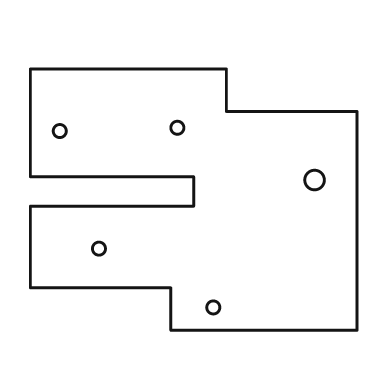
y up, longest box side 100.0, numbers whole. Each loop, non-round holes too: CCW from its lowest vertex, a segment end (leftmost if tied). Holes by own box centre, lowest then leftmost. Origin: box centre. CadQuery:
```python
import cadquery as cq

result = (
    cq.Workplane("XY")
    .moveTo(-7.0, -40.0)
    .lineTo(50.0, -40.0)
    .lineTo(50.0, 27.0)
    .lineTo(10.0, 27.0)
    .lineTo(10.0, 40.0)
    .lineTo(-50.0, 40.0)
    .lineTo(-50.0, 7.0)
    .lineTo(0.0, 7.0)
    .lineTo(0.0, -2.0)
    .lineTo(-50.0, -2.0)
    .lineTo(-50.0, -27.0)
    .lineTo(-7.0, -27.0)
    .close()
    .moveTo(6.0, -33.0)
    .circle(2.0)
    .moveTo(-29.0, -15.0)
    .circle(2.0)
    .moveTo(37.0, 6.0)
    .circle(3.0)
    .moveTo(-41.0, 21.0)
    .circle(2.0)
    .moveTo(-5.0, 22.0)
    .circle(2.0)
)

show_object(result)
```